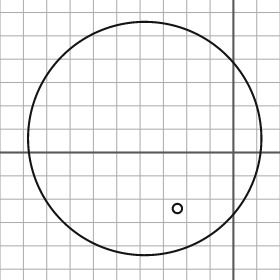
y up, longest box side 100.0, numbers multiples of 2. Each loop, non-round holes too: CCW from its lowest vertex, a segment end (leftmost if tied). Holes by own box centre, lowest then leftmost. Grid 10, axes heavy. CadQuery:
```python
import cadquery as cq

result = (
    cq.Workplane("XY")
    .moveTo(-38.0, 6.0)
    .circle(50.0)
    .moveTo(-24.0, -24.0)
    .circle(2.0)
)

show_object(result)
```